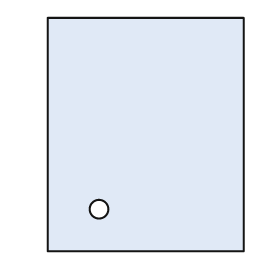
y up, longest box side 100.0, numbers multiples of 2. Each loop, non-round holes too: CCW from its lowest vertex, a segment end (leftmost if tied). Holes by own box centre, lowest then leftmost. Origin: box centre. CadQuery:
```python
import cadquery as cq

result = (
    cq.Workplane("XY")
    .moveTo(-42.0, -50.0)
    .lineTo(42.0, -50.0)
    .lineTo(42.0, 50.0)
    .lineTo(-42.0, 50.0)
    .close()
    .moveTo(-20.0, -32.0)
    .circle(4.0)
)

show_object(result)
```